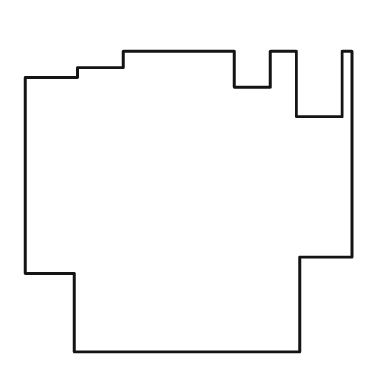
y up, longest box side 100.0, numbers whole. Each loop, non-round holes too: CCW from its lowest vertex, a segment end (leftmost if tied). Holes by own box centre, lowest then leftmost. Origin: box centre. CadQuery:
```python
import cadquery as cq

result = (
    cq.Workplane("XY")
    .moveTo(-35.0, -46.0)
    .lineTo(34.0, -46.0)
    .lineTo(34.0, -17.0)
    .lineTo(50.0, -17.0)
    .lineTo(50.0, 46.0)
    .lineTo(47.0, 46.0)
    .lineTo(47.0, 26.0)
    .lineTo(33.0, 26.0)
    .lineTo(33.0, 46.0)
    .lineTo(25.0, 46.0)
    .lineTo(25.0, 35.0)
    .lineTo(14.0, 35.0)
    .lineTo(14.0, 46.0)
    .lineTo(-20.0, 46.0)
    .lineTo(-20.0, 41.0)
    .lineTo(-34.0, 41.0)
    .lineTo(-34.0, 38.0)
    .lineTo(-50.0, 38.0)
    .lineTo(-50.0, -22.0)
    .lineTo(-35.0, -22.0)
    .close()
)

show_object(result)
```